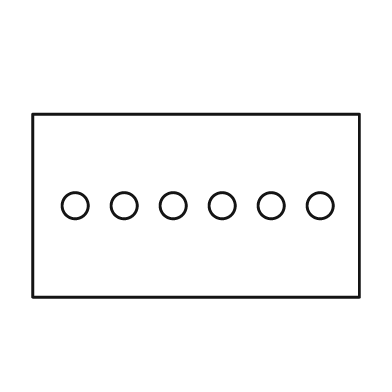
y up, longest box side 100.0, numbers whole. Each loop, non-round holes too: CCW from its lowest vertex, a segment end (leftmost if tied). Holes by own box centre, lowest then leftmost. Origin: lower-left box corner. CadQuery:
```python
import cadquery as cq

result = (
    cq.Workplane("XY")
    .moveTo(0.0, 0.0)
    .lineTo(100.0, 0.0)
    .lineTo(100.0, 56.0)
    .lineTo(0.0, 56.0)
    .close()
    .moveTo(13.0, 28.0)
    .circle(4.0)
    .moveTo(28.0, 28.0)
    .circle(4.0)
    .moveTo(43.0, 28.0)
    .circle(4.0)
    .moveTo(58.0, 28.0)
    .circle(4.0)
    .moveTo(73.0, 28.0)
    .circle(4.0)
    .moveTo(88.0, 28.0)
    .circle(4.0)
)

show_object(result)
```